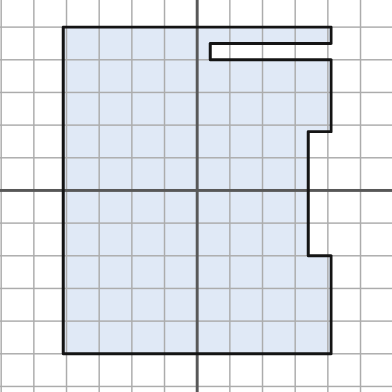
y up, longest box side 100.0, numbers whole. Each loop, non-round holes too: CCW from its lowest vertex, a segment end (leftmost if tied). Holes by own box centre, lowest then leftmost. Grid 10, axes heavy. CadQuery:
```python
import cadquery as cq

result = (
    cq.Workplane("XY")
    .moveTo(-41.0, -50.0)
    .lineTo(41.0, -50.0)
    .lineTo(41.0, -20.0)
    .lineTo(34.0, -20.0)
    .lineTo(34.0, 18.0)
    .lineTo(41.0, 18.0)
    .lineTo(41.0, 40.0)
    .lineTo(4.0, 40.0)
    .lineTo(4.0, 45.0)
    .lineTo(41.0, 45.0)
    .lineTo(41.0, 50.0)
    .lineTo(-41.0, 50.0)
    .close()
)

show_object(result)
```